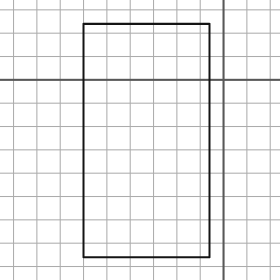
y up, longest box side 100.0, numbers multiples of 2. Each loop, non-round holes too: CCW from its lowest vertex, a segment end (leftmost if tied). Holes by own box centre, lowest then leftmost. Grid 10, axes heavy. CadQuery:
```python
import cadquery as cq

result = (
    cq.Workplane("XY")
    .moveTo(-60.0, -76.0)
    .lineTo(-6.0, -76.0)
    .lineTo(-6.0, 24.0)
    .lineTo(-60.0, 24.0)
    .close()
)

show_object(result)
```